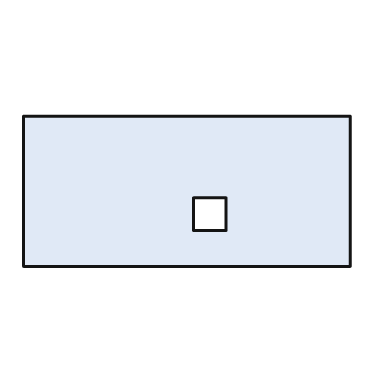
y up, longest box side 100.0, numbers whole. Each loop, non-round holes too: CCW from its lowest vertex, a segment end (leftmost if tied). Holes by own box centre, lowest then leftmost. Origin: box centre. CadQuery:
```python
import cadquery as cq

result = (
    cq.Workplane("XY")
    .moveTo(-50.0, -23.0)
    .lineTo(50.0, -23.0)
    .lineTo(50.0, 23.0)
    .lineTo(-50.0, 23.0)
    .close()
    .moveTo(2.0, -12.0)
    .lineTo(12.0, -12.0)
    .lineTo(12.0, -2.0)
    .lineTo(2.0, -2.0)
    .close()
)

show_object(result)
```